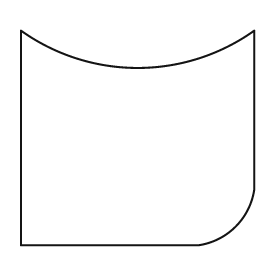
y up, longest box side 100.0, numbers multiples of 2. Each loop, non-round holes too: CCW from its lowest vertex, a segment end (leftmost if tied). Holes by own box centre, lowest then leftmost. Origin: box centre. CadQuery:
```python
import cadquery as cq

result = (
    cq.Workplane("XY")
    .moveTo(-50.0, -46.0)
    .lineTo(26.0, -46.0)
    .threePointArc((42.0, -38.0), (50.0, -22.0))
    .lineTo(50.0, 46.0)
    .threePointArc((0.0, 30.0), (-50.0, 46.0))
    .close()
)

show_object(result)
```